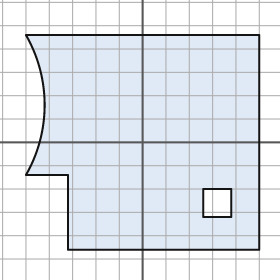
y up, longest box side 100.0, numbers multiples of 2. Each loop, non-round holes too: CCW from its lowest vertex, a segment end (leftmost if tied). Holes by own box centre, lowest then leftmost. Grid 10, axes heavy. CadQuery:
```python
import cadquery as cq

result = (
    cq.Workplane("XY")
    .moveTo(-32.0, -46.0)
    .lineTo(50.0, -46.0)
    .lineTo(50.0, 46.0)
    .lineTo(-50.0, 46.0)
    .threePointArc((-42.0, 16.0), (-50.0, -14.0))
    .lineTo(-32.0, -14.0)
    .close()
    .moveTo(26.0, -32.0)
    .lineTo(38.0, -32.0)
    .lineTo(38.0, -20.0)
    .lineTo(26.0, -20.0)
    .close()
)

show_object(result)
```